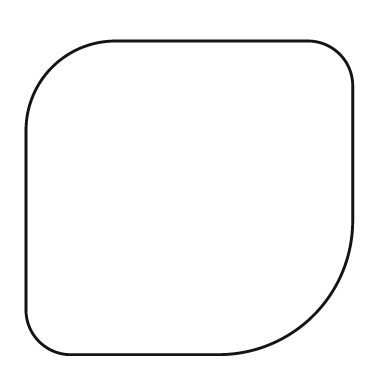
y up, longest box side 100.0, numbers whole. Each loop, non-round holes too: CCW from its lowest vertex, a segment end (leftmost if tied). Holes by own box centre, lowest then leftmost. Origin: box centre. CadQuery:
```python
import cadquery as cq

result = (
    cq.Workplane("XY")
    .moveTo(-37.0, -48.0)
    .lineTo(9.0, -48.0)
    .threePointArc((38.0, -36.0), (50.0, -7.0))
    .lineTo(50.0, 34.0)
    .threePointArc((46.0, 44.0), (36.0, 48.0))
    .lineTo(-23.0, 48.0)
    .threePointArc((-42.0, 40.0), (-50.0, 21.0))
    .lineTo(-50.0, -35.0)
    .threePointArc((-46.0, -44.0), (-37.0, -48.0))
    .close()
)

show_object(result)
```